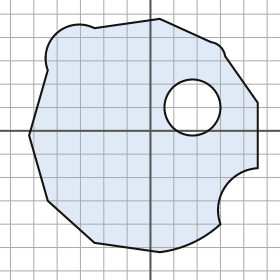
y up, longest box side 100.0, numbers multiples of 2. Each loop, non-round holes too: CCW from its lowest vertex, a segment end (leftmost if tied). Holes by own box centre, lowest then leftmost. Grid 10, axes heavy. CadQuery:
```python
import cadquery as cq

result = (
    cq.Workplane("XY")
    .moveTo(4.0, -52.0)
    .threePointArc((18.0, -48.0), (30.0, -40.0))
    .threePointArc((32.0, -24.0), (46.0, -16.0))
    .lineTo(46.0, 12.0)
    .lineTo(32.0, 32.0)
    .threePointArc((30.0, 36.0), (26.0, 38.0))
    .lineTo(4.0, 48.0)
    .lineTo(-24.0, 44.0)
    .threePointArc((-40.0, 42.0), (-44.0, 26.0))
    .lineTo(-52.0, -2.0)
    .lineTo(-44.0, -30.0)
    .lineTo(-24.0, -48.0)
    .close()
    .moveTo(18.0, 10.0)
    .circle(12.0)
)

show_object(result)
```